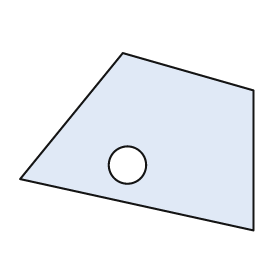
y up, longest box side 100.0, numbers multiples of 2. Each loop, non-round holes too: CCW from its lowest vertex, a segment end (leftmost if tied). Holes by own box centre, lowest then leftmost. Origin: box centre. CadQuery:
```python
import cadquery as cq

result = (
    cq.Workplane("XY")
    .moveTo(50.0, -38.0)
    .lineTo(50.0, 22.0)
    .lineTo(-6.0, 38.0)
    .lineTo(-50.0, -16.0)
    .close()
    .moveTo(-4.0, -10.0)
    .circle(8.0)
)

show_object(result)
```